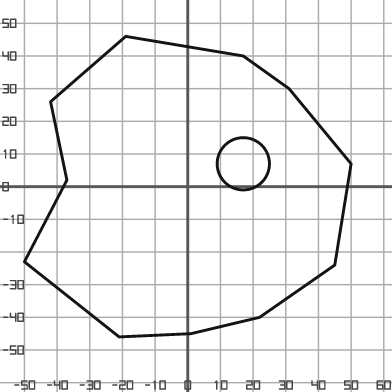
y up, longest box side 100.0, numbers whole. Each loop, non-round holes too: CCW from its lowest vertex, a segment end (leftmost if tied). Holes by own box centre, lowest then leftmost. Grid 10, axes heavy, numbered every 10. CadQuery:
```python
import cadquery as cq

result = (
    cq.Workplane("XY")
    .moveTo(-21.0, -46.0)
    .lineTo(1.0, -45.0)
    .lineTo(22.0, -40.0)
    .lineTo(45.0, -24.0)
    .lineTo(50.0, 7.0)
    .lineTo(31.0, 30.0)
    .lineTo(17.0, 40.0)
    .lineTo(-19.0, 46.0)
    .lineTo(-42.0, 26.0)
    .lineTo(-37.0, 2.0)
    .lineTo(-50.0, -23.0)
    .close()
    .moveTo(17.0, 7.0)
    .circle(8.0)
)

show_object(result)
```